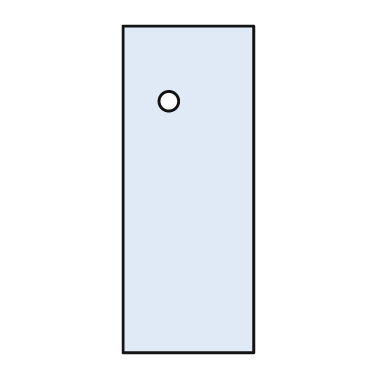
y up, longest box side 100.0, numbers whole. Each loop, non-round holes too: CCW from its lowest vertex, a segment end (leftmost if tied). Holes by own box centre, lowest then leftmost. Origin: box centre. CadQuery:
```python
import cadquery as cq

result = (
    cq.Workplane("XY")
    .moveTo(-20.0, -50.0)
    .lineTo(20.0, -50.0)
    .lineTo(20.0, 50.0)
    .lineTo(-20.0, 50.0)
    .close()
    .moveTo(-6.0, 27.0)
    .circle(3.0)
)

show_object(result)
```